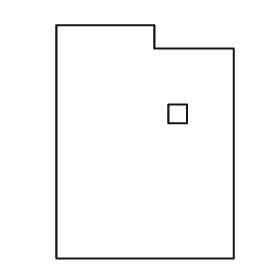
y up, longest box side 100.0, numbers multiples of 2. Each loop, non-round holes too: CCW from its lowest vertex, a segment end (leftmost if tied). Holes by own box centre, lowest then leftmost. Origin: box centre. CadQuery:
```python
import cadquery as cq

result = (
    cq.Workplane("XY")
    .moveTo(-38.0, -50.0)
    .lineTo(38.0, -50.0)
    .lineTo(38.0, 40.0)
    .lineTo(4.0, 40.0)
    .lineTo(4.0, 50.0)
    .lineTo(-38.0, 50.0)
    .close()
    .moveTo(10.0, 8.0)
    .lineTo(18.0, 8.0)
    .lineTo(18.0, 16.0)
    .lineTo(10.0, 16.0)
    .close()
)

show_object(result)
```